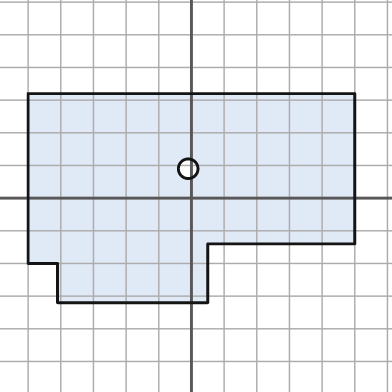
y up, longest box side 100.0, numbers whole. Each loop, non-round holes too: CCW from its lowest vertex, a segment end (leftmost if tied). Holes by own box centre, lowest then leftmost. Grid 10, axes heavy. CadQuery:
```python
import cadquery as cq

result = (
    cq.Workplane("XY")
    .moveTo(-41.0, -32.0)
    .lineTo(5.0, -32.0)
    .lineTo(5.0, -14.0)
    .lineTo(50.0, -14.0)
    .lineTo(50.0, 32.0)
    .lineTo(-50.0, 32.0)
    .lineTo(-50.0, -20.0)
    .lineTo(-41.0, -20.0)
    .close()
    .moveTo(-1.0, 9.0)
    .circle(3.0)
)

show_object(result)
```